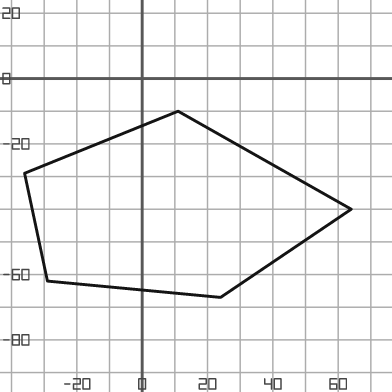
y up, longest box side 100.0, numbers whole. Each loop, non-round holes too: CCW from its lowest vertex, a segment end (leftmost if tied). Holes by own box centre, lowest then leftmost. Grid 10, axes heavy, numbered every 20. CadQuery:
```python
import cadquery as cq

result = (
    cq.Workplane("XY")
    .moveTo(24.0, -67.0)
    .lineTo(64.0, -40.0)
    .lineTo(11.0, -10.0)
    .lineTo(-36.0, -29.0)
    .lineTo(-29.0, -62.0)
    .close()
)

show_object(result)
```